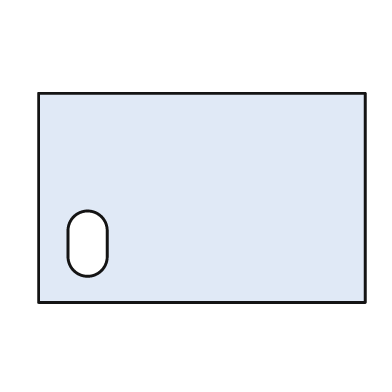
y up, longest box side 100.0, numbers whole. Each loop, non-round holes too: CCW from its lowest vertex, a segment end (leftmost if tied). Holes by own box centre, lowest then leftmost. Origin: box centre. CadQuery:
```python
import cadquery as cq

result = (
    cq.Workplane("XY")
    .moveTo(-50.0, -32.0)
    .lineTo(50.0, -32.0)
    .lineTo(50.0, 32.0)
    .lineTo(-50.0, 32.0)
    .close()
    .moveTo(-41.0, -18.0)
    .threePointArc((-35.0, -24.0), (-29.0, -18.0))
    .lineTo(-29.0, -10.0)
    .threePointArc((-35.0, -4.0), (-41.0, -10.0))
    .close()
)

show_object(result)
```